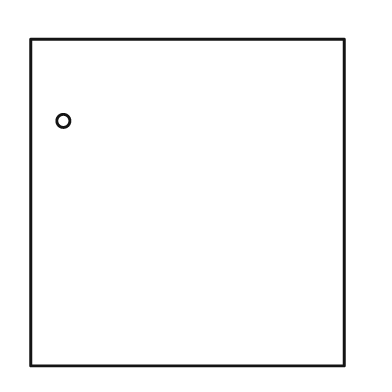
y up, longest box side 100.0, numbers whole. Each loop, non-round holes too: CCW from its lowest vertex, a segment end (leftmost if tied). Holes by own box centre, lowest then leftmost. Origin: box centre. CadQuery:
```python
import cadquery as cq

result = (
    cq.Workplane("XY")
    .moveTo(-48.0, -50.0)
    .lineTo(48.0, -50.0)
    .lineTo(48.0, 50.0)
    .lineTo(-48.0, 50.0)
    .close()
    .moveTo(-38.0, 25.0)
    .circle(2.0)
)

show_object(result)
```